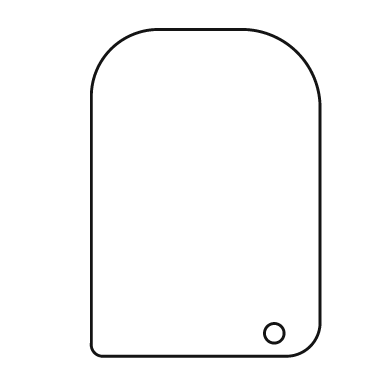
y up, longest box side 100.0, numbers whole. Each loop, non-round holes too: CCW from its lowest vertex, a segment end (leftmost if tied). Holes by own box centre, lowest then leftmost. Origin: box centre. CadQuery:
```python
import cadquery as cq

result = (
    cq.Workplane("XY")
    .moveTo(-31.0, -50.0)
    .lineTo(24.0, -50.0)
    .threePointArc((32.0, -47.0), (35.0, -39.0))
    .lineTo(35.0, 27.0)
    .threePointArc((28.0, 43.0), (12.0, 50.0))
    .lineTo(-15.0, 50.0)
    .threePointArc((-29.0, 44.0), (-35.0, 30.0))
    .lineTo(-35.0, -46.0)
    .threePointArc((-34.0, -49.0), (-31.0, -50.0))
    .close()
    .moveTo(21.0, -43.0)
    .circle(3.0)
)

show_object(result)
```